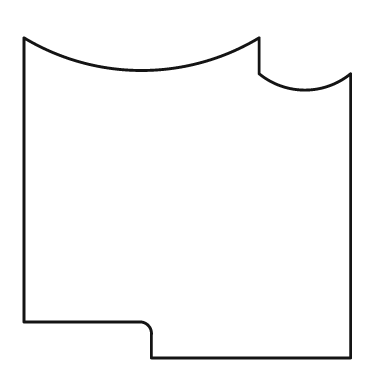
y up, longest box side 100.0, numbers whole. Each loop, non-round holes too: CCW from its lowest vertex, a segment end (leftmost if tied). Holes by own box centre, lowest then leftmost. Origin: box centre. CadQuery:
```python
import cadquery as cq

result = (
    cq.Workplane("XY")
    .moveTo(-11.0, -49.0)
    .lineTo(50.0, -49.0)
    .lineTo(50.0, 38.0)
    .threePointArc((36.0, 33.0), (22.0, 38.0))
    .lineTo(22.0, 49.0)
    .threePointArc((-14.0, 39.0), (-50.0, 49.0))
    .lineTo(-50.0, -38.0)
    .lineTo(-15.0, -38.0)
    .threePointArc((-12.0, -39.0), (-11.0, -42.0))
    .close()
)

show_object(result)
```